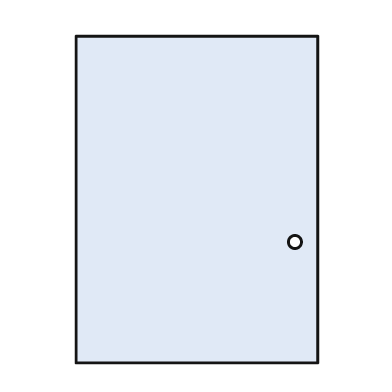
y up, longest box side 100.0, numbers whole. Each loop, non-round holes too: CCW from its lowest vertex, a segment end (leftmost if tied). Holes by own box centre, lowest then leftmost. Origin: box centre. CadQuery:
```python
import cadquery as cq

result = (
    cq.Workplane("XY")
    .moveTo(-37.0, -50.0)
    .lineTo(37.0, -50.0)
    .lineTo(37.0, 50.0)
    .lineTo(-37.0, 50.0)
    .close()
    .moveTo(30.0, -13.0)
    .circle(2.0)
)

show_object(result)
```